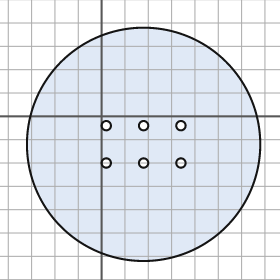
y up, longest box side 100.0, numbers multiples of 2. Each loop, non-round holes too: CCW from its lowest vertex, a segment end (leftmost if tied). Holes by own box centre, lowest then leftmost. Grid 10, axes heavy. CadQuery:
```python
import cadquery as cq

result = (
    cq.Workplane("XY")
    .moveTo(18.0, -12.0)
    .circle(50.0)
    .moveTo(2.0, -20.0)
    .circle(2.0)
    .moveTo(18.0, -20.0)
    .circle(2.0)
    .moveTo(34.0, -20.0)
    .circle(2.0)
    .moveTo(2.0, -4.0)
    .circle(2.0)
    .moveTo(18.0, -4.0)
    .circle(2.0)
    .moveTo(34.0, -4.0)
    .circle(2.0)
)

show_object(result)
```